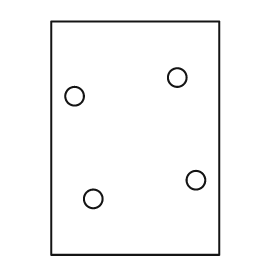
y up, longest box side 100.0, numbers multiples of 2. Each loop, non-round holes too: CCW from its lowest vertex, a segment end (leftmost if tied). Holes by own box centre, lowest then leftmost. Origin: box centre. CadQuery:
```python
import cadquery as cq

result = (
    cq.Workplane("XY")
    .moveTo(-36.0, -50.0)
    .lineTo(36.0, -50.0)
    .lineTo(36.0, 50.0)
    .lineTo(-36.0, 50.0)
    .close()
    .moveTo(-18.0, -26.0)
    .circle(4.0)
    .moveTo(26.0, -18.0)
    .circle(4.0)
    .moveTo(-26.0, 18.0)
    .circle(4.0)
    .moveTo(18.0, 26.0)
    .circle(4.0)
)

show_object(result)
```